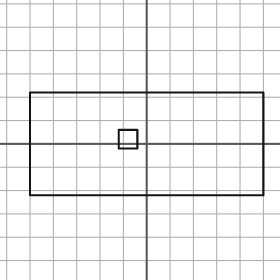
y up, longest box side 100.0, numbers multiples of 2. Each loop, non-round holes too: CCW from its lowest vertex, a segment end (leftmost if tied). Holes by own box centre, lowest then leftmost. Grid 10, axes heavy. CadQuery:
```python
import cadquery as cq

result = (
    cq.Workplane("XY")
    .moveTo(-50.0, -22.0)
    .lineTo(50.0, -22.0)
    .lineTo(50.0, 22.0)
    .lineTo(-50.0, 22.0)
    .close()
    .moveTo(-12.0, -2.0)
    .lineTo(-4.0, -2.0)
    .lineTo(-4.0, 6.0)
    .lineTo(-12.0, 6.0)
    .close()
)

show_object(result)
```